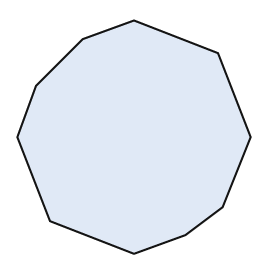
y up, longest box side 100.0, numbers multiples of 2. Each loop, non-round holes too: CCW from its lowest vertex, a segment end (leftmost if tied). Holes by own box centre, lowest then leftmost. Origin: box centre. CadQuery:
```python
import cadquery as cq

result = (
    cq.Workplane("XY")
    .moveTo(0.0, -50.0)
    .lineTo(22.0, -42.0)
    .lineTo(38.0, -30.0)
    .lineTo(50.0, 0.0)
    .lineTo(36.0, 36.0)
    .lineTo(0.0, 50.0)
    .lineTo(-22.0, 42.0)
    .lineTo(-42.0, 22.0)
    .lineTo(-50.0, 0.0)
    .lineTo(-36.0, -36.0)
    .close()
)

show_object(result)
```